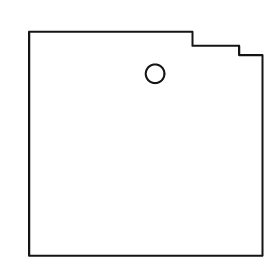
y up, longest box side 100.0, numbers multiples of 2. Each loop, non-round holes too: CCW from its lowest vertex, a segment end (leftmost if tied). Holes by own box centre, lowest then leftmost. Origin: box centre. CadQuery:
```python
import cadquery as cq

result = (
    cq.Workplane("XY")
    .moveTo(-50.0, -48.0)
    .lineTo(50.0, -48.0)
    .lineTo(50.0, 38.0)
    .lineTo(40.0, 38.0)
    .lineTo(40.0, 42.0)
    .lineTo(20.0, 42.0)
    .lineTo(20.0, 48.0)
    .lineTo(-50.0, 48.0)
    .close()
    .moveTo(4.0, 30.0)
    .circle(4.0)
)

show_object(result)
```